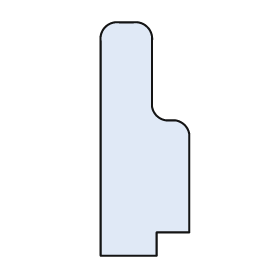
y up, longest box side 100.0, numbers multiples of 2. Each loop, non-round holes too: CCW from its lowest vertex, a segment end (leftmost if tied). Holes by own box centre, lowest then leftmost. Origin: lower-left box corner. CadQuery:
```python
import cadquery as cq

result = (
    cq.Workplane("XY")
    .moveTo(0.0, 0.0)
    .lineTo(24.0, 0.0)
    .lineTo(24.0, 10.0)
    .lineTo(38.0, 10.0)
    .lineTo(38.0, 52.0)
    .threePointArc((36.0, 56.0), (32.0, 58.0))
    .lineTo(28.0, 58.0)
    .threePointArc((24.0, 60.0), (22.0, 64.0))
    .lineTo(22.0, 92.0)
    .threePointArc((20.0, 98.0), (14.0, 100.0))
    .lineTo(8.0, 100.0)
    .threePointArc((2.0, 98.0), (0.0, 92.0))
    .close()
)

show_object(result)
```